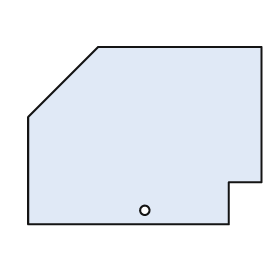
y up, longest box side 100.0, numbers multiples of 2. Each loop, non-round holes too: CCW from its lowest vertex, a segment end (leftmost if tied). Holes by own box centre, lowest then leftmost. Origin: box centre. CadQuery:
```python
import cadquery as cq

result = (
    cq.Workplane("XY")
    .moveTo(-50.0, -38.0)
    .lineTo(36.0, -38.0)
    .lineTo(36.0, -20.0)
    .lineTo(50.0, -20.0)
    .lineTo(50.0, 38.0)
    .lineTo(-20.0, 38.0)
    .lineTo(-50.0, 8.0)
    .close()
    .moveTo(0.0, -32.0)
    .circle(2.0)
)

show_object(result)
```